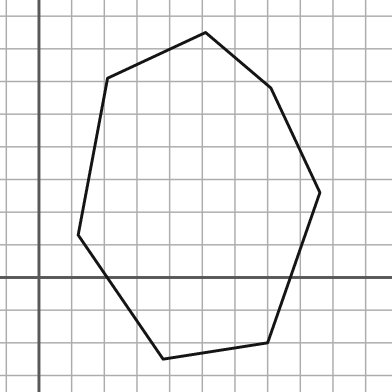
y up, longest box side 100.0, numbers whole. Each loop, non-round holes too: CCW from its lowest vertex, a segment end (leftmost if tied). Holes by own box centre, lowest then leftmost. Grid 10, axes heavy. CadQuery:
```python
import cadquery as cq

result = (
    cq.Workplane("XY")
    .moveTo(38.0, -25.0)
    .lineTo(70.0, -20.0)
    .lineTo(86.0, 26.0)
    .lineTo(71.0, 58.0)
    .lineTo(51.0, 75.0)
    .lineTo(21.0, 61.0)
    .lineTo(12.0, 13.0)
    .close()
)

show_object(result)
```